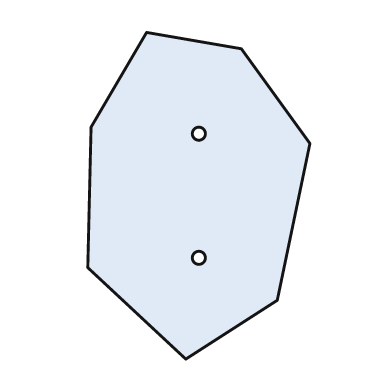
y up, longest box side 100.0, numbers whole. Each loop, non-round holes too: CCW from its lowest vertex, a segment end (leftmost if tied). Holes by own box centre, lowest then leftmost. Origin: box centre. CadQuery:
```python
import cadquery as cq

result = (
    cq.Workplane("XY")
    .moveTo(-4.0, -50.0)
    .lineTo(24.0, -32.0)
    .lineTo(34.0, 16.0)
    .lineTo(13.0, 45.0)
    .lineTo(-16.0, 50.0)
    .lineTo(-33.0, 21.0)
    .lineTo(-34.0, -22.0)
    .close()
    .moveTo(0.0, -19.0)
    .circle(2.0)
    .moveTo(0.0, 19.0)
    .circle(2.0)
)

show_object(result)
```